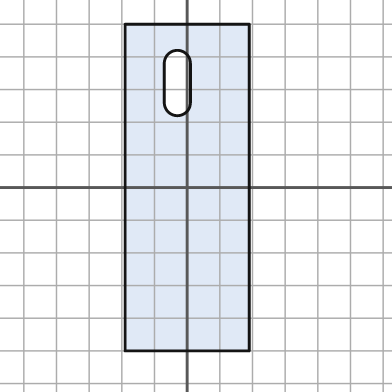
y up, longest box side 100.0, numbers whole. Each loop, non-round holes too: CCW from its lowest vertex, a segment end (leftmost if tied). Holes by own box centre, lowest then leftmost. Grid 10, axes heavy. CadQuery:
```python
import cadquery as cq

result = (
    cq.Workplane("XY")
    .moveTo(-19.0, -50.0)
    .lineTo(19.0, -50.0)
    .lineTo(19.0, 50.0)
    .lineTo(-19.0, 50.0)
    .close()
    .moveTo(-7.0, 26.0)
    .threePointArc((-3.0, 22.0), (1.0, 26.0))
    .lineTo(1.0, 38.0)
    .threePointArc((-3.0, 42.0), (-7.0, 38.0))
    .close()
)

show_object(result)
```